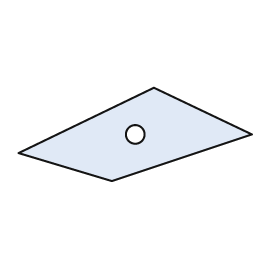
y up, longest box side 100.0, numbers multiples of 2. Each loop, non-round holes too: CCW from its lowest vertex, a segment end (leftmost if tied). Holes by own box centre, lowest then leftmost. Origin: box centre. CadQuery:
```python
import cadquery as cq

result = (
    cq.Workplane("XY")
    .moveTo(-10.0, -20.0)
    .lineTo(50.0, 0.0)
    .lineTo(8.0, 20.0)
    .lineTo(-50.0, -8.0)
    .close()
    .moveTo(0.0, 0.0)
    .circle(4.0)
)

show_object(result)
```